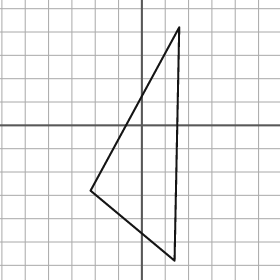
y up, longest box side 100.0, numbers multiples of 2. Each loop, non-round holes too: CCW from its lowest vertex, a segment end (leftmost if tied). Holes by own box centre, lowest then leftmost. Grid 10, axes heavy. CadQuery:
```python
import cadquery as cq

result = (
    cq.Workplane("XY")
    .moveTo(14.0, -58.0)
    .lineTo(16.0, 42.0)
    .lineTo(-22.0, -28.0)
    .close()
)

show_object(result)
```